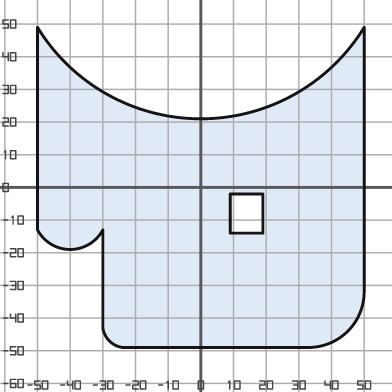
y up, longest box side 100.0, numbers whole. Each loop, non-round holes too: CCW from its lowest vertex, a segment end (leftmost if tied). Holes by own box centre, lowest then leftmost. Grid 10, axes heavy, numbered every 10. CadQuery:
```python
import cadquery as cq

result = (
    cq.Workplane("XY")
    .moveTo(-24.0, -49.0)
    .lineTo(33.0, -49.0)
    .threePointArc((45.0, -44.0), (50.0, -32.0))
    .lineTo(50.0, 49.0)
    .threePointArc((0.0, 21.0), (-50.0, 49.0))
    .lineTo(-50.0, -13.0)
    .threePointArc((-40.0, -19.0), (-30.0, -13.0))
    .lineTo(-30.0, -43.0)
    .threePointArc((-28.0, -47.0), (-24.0, -49.0))
    .close()
    .moveTo(9.0, -14.0)
    .lineTo(19.0, -14.0)
    .lineTo(19.0, -2.0)
    .lineTo(9.0, -2.0)
    .close()
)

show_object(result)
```